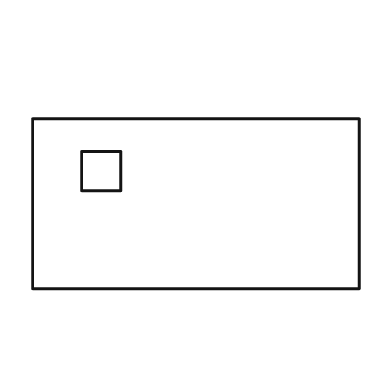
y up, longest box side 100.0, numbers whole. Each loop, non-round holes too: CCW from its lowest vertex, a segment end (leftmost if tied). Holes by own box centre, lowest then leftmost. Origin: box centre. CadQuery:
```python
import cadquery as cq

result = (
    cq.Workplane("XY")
    .moveTo(-50.0, -26.0)
    .lineTo(50.0, -26.0)
    .lineTo(50.0, 26.0)
    .lineTo(-50.0, 26.0)
    .close()
    .moveTo(-35.0, 4.0)
    .lineTo(-23.0, 4.0)
    .lineTo(-23.0, 16.0)
    .lineTo(-35.0, 16.0)
    .close()
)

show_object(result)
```